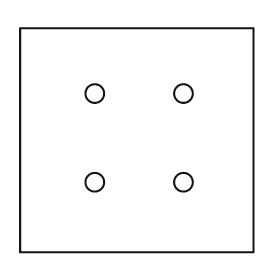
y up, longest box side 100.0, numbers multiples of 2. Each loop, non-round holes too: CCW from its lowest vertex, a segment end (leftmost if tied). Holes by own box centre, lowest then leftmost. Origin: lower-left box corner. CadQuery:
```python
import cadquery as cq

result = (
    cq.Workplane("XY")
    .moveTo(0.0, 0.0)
    .lineTo(100.0, 0.0)
    .lineTo(100.0, 96.0)
    .lineTo(0.0, 96.0)
    .close()
    .moveTo(32.0, 30.0)
    .circle(4.0)
    .moveTo(70.0, 30.0)
    .circle(4.0)
    .moveTo(32.0, 68.0)
    .circle(4.0)
    .moveTo(70.0, 68.0)
    .circle(4.0)
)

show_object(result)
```